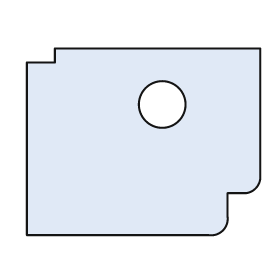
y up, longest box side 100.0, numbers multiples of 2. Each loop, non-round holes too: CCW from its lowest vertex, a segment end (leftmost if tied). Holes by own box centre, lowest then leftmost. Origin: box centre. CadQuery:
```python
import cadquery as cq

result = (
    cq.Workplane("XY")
    .moveTo(-50.0, -40.0)
    .lineTo(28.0, -40.0)
    .threePointArc((34.0, -38.0), (36.0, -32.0))
    .lineTo(36.0, -22.0)
    .lineTo(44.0, -22.0)
    .threePointArc((48.0, -20.0), (50.0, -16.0))
    .lineTo(50.0, 40.0)
    .lineTo(-38.0, 40.0)
    .lineTo(-38.0, 34.0)
    .lineTo(-50.0, 34.0)
    .close()
    .moveTo(8.0, 16.0)
    .circle(10.0)
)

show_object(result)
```